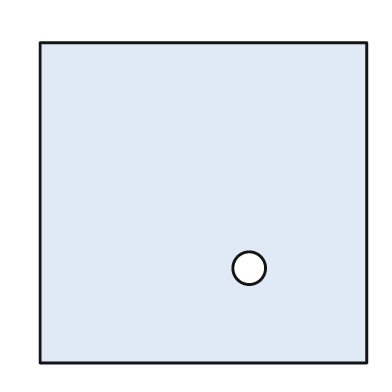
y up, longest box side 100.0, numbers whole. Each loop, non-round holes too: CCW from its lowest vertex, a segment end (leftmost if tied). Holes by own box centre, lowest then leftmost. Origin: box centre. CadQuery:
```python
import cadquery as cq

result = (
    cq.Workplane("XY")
    .moveTo(-50.0, -49.0)
    .lineTo(50.0, -49.0)
    .lineTo(50.0, 49.0)
    .lineTo(-50.0, 49.0)
    .close()
    .moveTo(14.0, -20.0)
    .circle(5.0)
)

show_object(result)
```